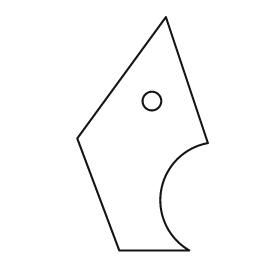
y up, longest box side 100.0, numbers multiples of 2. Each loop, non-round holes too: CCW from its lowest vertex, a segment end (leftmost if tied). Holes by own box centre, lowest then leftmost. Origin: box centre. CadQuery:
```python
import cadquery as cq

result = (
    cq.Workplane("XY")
    .moveTo(-10.0, -50.0)
    .lineTo(20.0, -50.0)
    .threePointArc((8.0, -24.0), (28.0, -4.0))
    .lineTo(10.0, 50.0)
    .lineTo(-28.0, -2.0)
    .close()
    .moveTo(4.0, 14.0)
    .circle(4.0)
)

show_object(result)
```